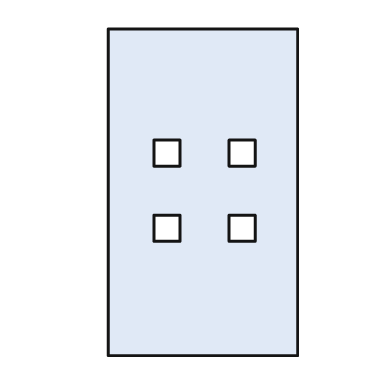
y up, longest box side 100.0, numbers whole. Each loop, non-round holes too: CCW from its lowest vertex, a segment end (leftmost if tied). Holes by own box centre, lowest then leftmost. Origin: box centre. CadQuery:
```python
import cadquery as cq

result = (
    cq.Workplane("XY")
    .moveTo(-29.0, -50.0)
    .lineTo(29.0, -50.0)
    .lineTo(29.0, 50.0)
    .lineTo(-29.0, 50.0)
    .close()
    .moveTo(-15.0, -15.0)
    .lineTo(-7.0, -15.0)
    .lineTo(-7.0, -7.0)
    .lineTo(-15.0, -7.0)
    .close()
    .moveTo(8.0, -15.0)
    .lineTo(16.0, -15.0)
    .lineTo(16.0, -7.0)
    .lineTo(8.0, -7.0)
    .close()
    .moveTo(-15.0, 8.0)
    .lineTo(-7.0, 8.0)
    .lineTo(-7.0, 16.0)
    .lineTo(-15.0, 16.0)
    .close()
    .moveTo(8.0, 8.0)
    .lineTo(16.0, 8.0)
    .lineTo(16.0, 16.0)
    .lineTo(8.0, 16.0)
    .close()
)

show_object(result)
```